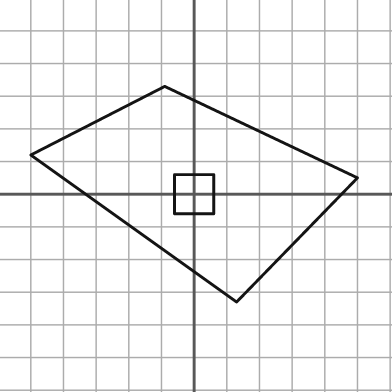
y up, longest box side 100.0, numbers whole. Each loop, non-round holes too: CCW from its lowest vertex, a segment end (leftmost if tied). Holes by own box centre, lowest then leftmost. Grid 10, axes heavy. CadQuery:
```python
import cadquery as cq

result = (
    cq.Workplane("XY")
    .moveTo(13.0, -33.0)
    .lineTo(50.0, 5.0)
    .lineTo(-9.0, 33.0)
    .lineTo(-50.0, 12.0)
    .close()
    .moveTo(-6.0, -6.0)
    .lineTo(6.0, -6.0)
    .lineTo(6.0, 6.0)
    .lineTo(-6.0, 6.0)
    .close()
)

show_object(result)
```